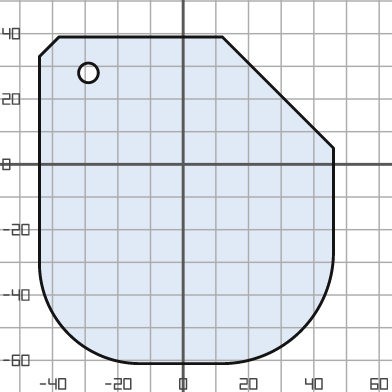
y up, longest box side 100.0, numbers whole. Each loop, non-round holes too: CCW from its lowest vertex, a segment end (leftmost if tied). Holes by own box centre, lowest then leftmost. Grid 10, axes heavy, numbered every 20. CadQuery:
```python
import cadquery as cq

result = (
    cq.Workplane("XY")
    .moveTo(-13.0, -61.0)
    .lineTo(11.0, -61.0)
    .threePointArc((36.0, -51.0), (46.0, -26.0))
    .lineTo(46.0, 5.0)
    .lineTo(12.0, 39.0)
    .lineTo(-38.0, 39.0)
    .lineTo(-44.0, 33.0)
    .lineTo(-44.0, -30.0)
    .threePointArc((-35.0, -52.0), (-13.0, -61.0))
    .close()
    .moveTo(-29.0, 28.0)
    .circle(3.0)
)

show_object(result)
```